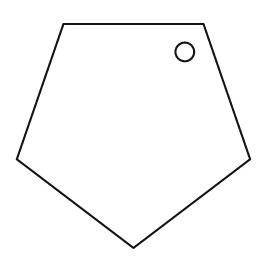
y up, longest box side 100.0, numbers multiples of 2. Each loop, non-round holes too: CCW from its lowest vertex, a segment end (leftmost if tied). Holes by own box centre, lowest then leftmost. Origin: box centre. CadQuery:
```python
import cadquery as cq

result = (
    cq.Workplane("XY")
    .moveTo(0.0, -48.0)
    .lineTo(50.0, -10.0)
    .lineTo(30.0, 48.0)
    .lineTo(-30.0, 48.0)
    .lineTo(-50.0, -10.0)
    .close()
    .moveTo(22.0, 36.0)
    .circle(4.0)
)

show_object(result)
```